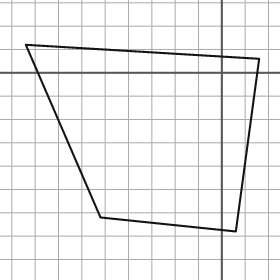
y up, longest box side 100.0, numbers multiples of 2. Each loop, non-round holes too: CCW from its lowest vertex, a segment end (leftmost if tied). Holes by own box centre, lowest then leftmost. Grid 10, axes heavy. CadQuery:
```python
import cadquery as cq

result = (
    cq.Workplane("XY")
    .moveTo(6.0, -68.0)
    .lineTo(16.0, 6.0)
    .lineTo(-84.0, 12.0)
    .lineTo(-52.0, -62.0)
    .close()
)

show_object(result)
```